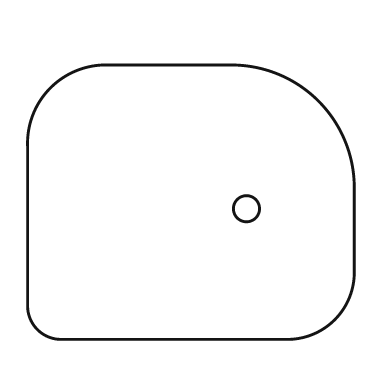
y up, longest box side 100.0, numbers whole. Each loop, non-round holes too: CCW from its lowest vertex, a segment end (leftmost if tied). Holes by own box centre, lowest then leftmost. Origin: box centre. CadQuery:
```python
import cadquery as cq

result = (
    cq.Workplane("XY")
    .moveTo(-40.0, -42.0)
    .lineTo(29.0, -42.0)
    .threePointArc((44.0, -36.0), (50.0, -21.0))
    .lineTo(50.0, 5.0)
    .threePointArc((39.0, 31.0), (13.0, 42.0))
    .lineTo(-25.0, 42.0)
    .threePointArc((-43.0, 35.0), (-50.0, 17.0))
    .lineTo(-50.0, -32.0)
    .threePointArc((-47.0, -39.0), (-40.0, -42.0))
    .close()
    .moveTo(17.0, -2.0)
    .circle(4.0)
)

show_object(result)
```